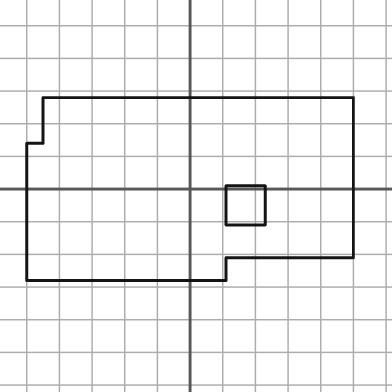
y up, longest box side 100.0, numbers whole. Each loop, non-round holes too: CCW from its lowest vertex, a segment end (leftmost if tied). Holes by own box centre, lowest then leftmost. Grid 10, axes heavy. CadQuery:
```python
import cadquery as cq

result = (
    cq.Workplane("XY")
    .moveTo(-50.0, -28.0)
    .lineTo(11.0, -28.0)
    .lineTo(11.0, -21.0)
    .lineTo(50.0, -21.0)
    .lineTo(50.0, 28.0)
    .lineTo(-45.0, 28.0)
    .lineTo(-45.0, 14.0)
    .lineTo(-50.0, 14.0)
    .close()
    .moveTo(11.0, -11.0)
    .lineTo(23.0, -11.0)
    .lineTo(23.0, 1.0)
    .lineTo(11.0, 1.0)
    .close()
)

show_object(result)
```